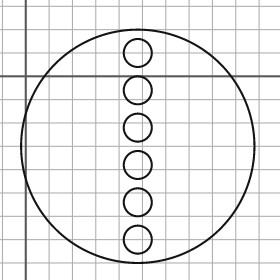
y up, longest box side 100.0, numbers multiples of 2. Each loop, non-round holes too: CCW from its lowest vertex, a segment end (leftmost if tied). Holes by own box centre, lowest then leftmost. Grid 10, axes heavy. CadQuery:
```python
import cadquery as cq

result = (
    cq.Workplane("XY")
    .moveTo(48.0, -30.0)
    .circle(50.0)
    .moveTo(48.0, -70.0)
    .circle(6.0)
    .moveTo(48.0, -54.0)
    .circle(6.0)
    .moveTo(48.0, -38.0)
    .circle(6.0)
    .moveTo(48.0, -22.0)
    .circle(6.0)
    .moveTo(48.0, -6.0)
    .circle(6.0)
    .moveTo(48.0, 10.0)
    .circle(6.0)
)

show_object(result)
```